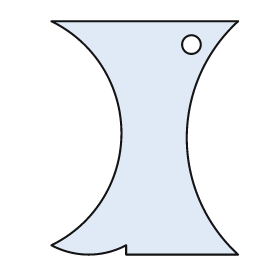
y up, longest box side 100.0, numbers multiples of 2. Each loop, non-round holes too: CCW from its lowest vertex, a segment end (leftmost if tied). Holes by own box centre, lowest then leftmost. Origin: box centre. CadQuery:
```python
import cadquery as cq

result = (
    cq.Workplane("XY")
    .moveTo(-8.0, -50.0)
    .lineTo(40.0, -50.0)
    .threePointArc((18.0, 0.0), (40.0, 50.0))
    .lineTo(-40.0, 50.0)
    .threePointArc((-10.0, 2.0), (-40.0, -46.0))
    .threePointArc((-24.0, -50.0), (-8.0, -46.0))
    .close()
    .moveTo(20.0, 40.0)
    .circle(4.0)
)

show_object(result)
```